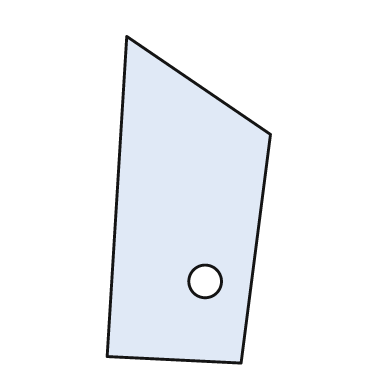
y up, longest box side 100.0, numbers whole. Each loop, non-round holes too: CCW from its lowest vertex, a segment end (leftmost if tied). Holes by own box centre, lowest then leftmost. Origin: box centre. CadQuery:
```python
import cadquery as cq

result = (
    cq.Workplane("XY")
    .moveTo(16.0, -50.0)
    .lineTo(25.0, 20.0)
    .lineTo(-19.0, 50.0)
    .lineTo(-25.0, -48.0)
    .close()
    .moveTo(5.0, -25.0)
    .circle(5.0)
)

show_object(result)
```